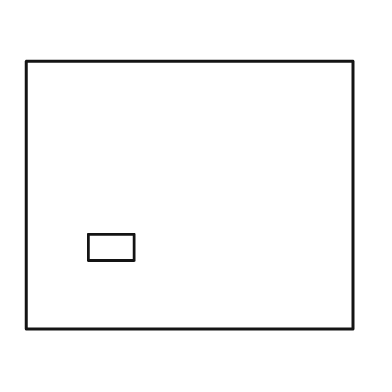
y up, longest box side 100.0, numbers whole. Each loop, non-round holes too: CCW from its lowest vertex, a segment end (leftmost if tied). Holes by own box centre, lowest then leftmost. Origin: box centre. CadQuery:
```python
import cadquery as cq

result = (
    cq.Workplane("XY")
    .moveTo(-50.0, -41.0)
    .lineTo(50.0, -41.0)
    .lineTo(50.0, 41.0)
    .lineTo(-50.0, 41.0)
    .close()
    .moveTo(-31.0, -20.0)
    .lineTo(-17.0, -20.0)
    .lineTo(-17.0, -12.0)
    .lineTo(-31.0, -12.0)
    .close()
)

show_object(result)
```